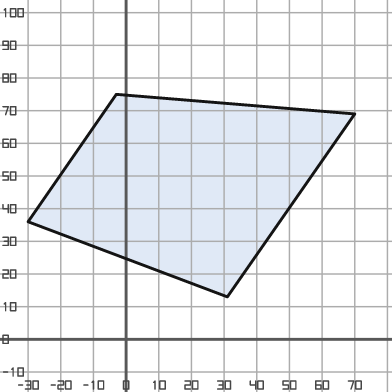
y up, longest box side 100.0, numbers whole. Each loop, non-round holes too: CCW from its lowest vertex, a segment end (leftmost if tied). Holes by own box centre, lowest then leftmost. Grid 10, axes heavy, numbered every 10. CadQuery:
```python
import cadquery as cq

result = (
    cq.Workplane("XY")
    .moveTo(31.0, 13.0)
    .lineTo(70.0, 69.0)
    .lineTo(-3.0, 75.0)
    .lineTo(-30.0, 36.0)
    .close()
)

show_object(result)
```